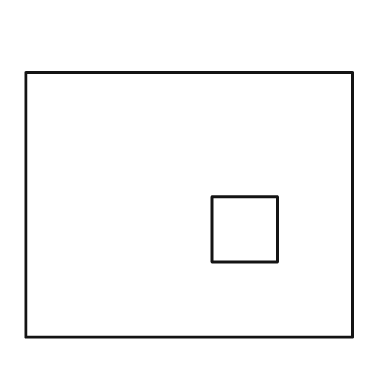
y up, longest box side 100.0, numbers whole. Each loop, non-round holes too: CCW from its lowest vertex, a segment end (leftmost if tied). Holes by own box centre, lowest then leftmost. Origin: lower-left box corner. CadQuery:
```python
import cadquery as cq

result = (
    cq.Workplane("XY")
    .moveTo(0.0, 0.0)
    .lineTo(100.0, 0.0)
    .lineTo(100.0, 81.0)
    .lineTo(0.0, 81.0)
    .close()
    .moveTo(57.0, 23.0)
    .lineTo(77.0, 23.0)
    .lineTo(77.0, 43.0)
    .lineTo(57.0, 43.0)
    .close()
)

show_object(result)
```